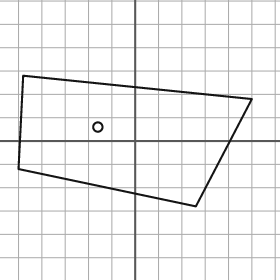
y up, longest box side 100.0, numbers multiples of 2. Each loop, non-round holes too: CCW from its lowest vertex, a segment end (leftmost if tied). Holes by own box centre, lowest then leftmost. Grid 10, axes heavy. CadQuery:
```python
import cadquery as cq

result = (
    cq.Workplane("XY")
    .moveTo(26.0, -28.0)
    .lineTo(50.0, 18.0)
    .lineTo(-48.0, 28.0)
    .lineTo(-50.0, -12.0)
    .close()
    .moveTo(-16.0, 6.0)
    .circle(2.0)
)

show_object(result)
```